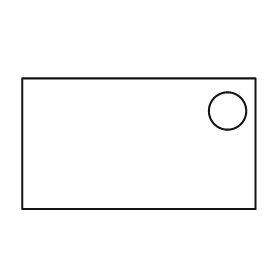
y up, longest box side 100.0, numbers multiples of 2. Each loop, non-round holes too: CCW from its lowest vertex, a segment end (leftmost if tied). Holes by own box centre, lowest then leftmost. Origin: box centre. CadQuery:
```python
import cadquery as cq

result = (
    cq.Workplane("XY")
    .moveTo(-50.0, -28.0)
    .lineTo(50.0, -28.0)
    .lineTo(50.0, 28.0)
    .lineTo(-50.0, 28.0)
    .close()
    .moveTo(38.0, 14.0)
    .circle(8.0)
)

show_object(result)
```